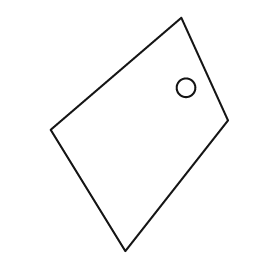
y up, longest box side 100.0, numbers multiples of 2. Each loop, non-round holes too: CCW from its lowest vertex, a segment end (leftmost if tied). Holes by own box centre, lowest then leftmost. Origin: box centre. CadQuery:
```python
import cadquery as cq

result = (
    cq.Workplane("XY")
    .moveTo(-6.0, -50.0)
    .lineTo(38.0, 6.0)
    .lineTo(18.0, 50.0)
    .lineTo(-38.0, 2.0)
    .close()
    .moveTo(20.0, 20.0)
    .circle(4.0)
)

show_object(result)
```